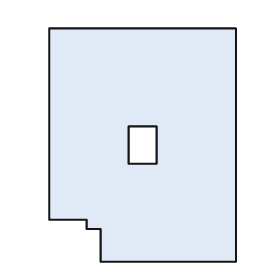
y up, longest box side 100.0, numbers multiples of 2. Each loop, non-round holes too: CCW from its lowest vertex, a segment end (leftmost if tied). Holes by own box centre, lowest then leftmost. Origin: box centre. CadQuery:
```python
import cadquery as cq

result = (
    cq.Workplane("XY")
    .moveTo(-18.0, -50.0)
    .lineTo(40.0, -50.0)
    .lineTo(40.0, 50.0)
    .lineTo(-40.0, 50.0)
    .lineTo(-40.0, -32.0)
    .lineTo(-24.0, -32.0)
    .lineTo(-24.0, -36.0)
    .lineTo(-18.0, -36.0)
    .close()
    .moveTo(-6.0, -8.0)
    .lineTo(6.0, -8.0)
    .lineTo(6.0, 8.0)
    .lineTo(-6.0, 8.0)
    .close()
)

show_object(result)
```